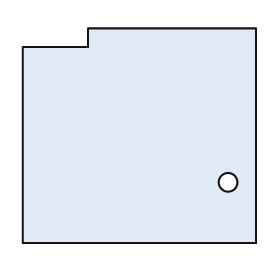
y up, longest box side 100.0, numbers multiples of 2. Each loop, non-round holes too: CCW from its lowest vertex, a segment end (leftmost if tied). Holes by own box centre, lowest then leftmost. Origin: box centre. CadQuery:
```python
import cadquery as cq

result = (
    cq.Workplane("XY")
    .moveTo(-50.0, -46.0)
    .lineTo(50.0, -46.0)
    .lineTo(50.0, 46.0)
    .lineTo(-22.0, 46.0)
    .lineTo(-22.0, 38.0)
    .lineTo(-50.0, 38.0)
    .close()
    .moveTo(38.0, -20.0)
    .circle(4.0)
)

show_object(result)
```